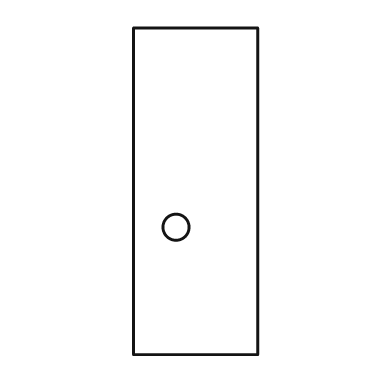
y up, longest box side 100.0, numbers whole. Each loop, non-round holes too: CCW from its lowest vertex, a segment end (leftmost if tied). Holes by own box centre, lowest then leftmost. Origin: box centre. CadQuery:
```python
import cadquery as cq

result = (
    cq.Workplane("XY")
    .moveTo(-19.0, -50.0)
    .lineTo(19.0, -50.0)
    .lineTo(19.0, 50.0)
    .lineTo(-19.0, 50.0)
    .close()
    .moveTo(-6.0, -11.0)
    .circle(4.0)
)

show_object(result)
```